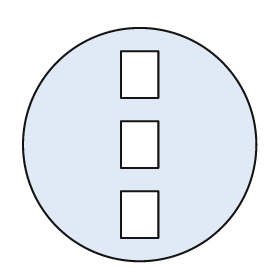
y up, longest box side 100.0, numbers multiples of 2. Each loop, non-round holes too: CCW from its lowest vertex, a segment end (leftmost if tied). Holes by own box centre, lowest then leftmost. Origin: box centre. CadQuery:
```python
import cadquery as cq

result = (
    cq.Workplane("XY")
    .moveTo(0.0, 0.0)
    .circle(50.0)
    .moveTo(-8.0, -40.0)
    .lineTo(8.0, -40.0)
    .lineTo(8.0, -20.0)
    .lineTo(-8.0, -20.0)
    .close()
    .moveTo(-8.0, -10.0)
    .lineTo(8.0, -10.0)
    .lineTo(8.0, 10.0)
    .lineTo(-8.0, 10.0)
    .close()
    .moveTo(-8.0, 20.0)
    .lineTo(8.0, 20.0)
    .lineTo(8.0, 40.0)
    .lineTo(-8.0, 40.0)
    .close()
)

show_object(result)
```